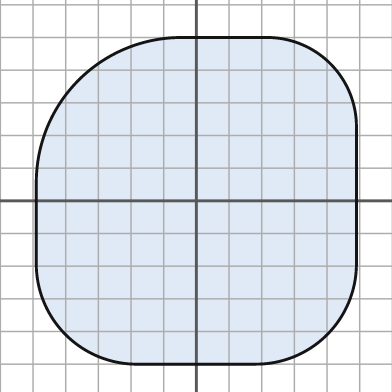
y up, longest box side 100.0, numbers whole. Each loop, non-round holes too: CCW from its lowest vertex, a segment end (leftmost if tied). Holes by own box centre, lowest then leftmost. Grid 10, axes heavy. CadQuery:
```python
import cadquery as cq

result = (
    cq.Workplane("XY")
    .moveTo(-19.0, -50.0)
    .lineTo(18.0, -50.0)
    .threePointArc((40.0, -41.0), (49.0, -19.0))
    .lineTo(49.0, 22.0)
    .threePointArc((41.0, 42.0), (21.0, 50.0))
    .lineTo(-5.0, 50.0)
    .threePointArc((-36.0, 37.0), (-49.0, 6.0))
    .lineTo(-49.0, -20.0)
    .threePointArc((-40.0, -41.0), (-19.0, -50.0))
    .close()
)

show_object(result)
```